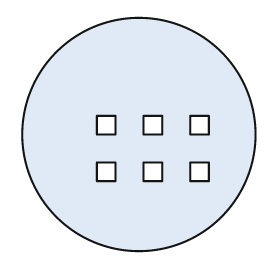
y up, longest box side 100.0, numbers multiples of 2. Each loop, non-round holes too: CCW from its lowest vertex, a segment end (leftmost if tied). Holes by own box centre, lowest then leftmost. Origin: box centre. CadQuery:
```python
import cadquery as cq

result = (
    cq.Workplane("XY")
    .moveTo(0.0, 0.0)
    .circle(50.0)
    .moveTo(-18.0, -20.0)
    .lineTo(-10.0, -20.0)
    .lineTo(-10.0, -12.0)
    .lineTo(-18.0, -12.0)
    .close()
    .moveTo(2.0, -20.0)
    .lineTo(10.0, -20.0)
    .lineTo(10.0, -12.0)
    .lineTo(2.0, -12.0)
    .close()
    .moveTo(22.0, -20.0)
    .lineTo(30.0, -20.0)
    .lineTo(30.0, -12.0)
    .lineTo(22.0, -12.0)
    .close()
    .moveTo(-18.0, 0.0)
    .lineTo(-10.0, 0.0)
    .lineTo(-10.0, 8.0)
    .lineTo(-18.0, 8.0)
    .close()
    .moveTo(2.0, 0.0)
    .lineTo(10.0, 0.0)
    .lineTo(10.0, 8.0)
    .lineTo(2.0, 8.0)
    .close()
    .moveTo(22.0, 0.0)
    .lineTo(30.0, 0.0)
    .lineTo(30.0, 8.0)
    .lineTo(22.0, 8.0)
    .close()
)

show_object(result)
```